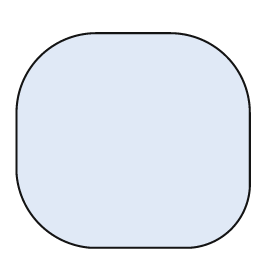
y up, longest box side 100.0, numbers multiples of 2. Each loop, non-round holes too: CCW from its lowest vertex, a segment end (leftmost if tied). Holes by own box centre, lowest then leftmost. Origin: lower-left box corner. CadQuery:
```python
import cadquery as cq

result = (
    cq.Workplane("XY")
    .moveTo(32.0, 0.0)
    .lineTo(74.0, 0.0)
    .threePointArc((92.0, 8.0), (100.0, 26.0))
    .lineTo(100.0, 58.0)
    .threePointArc((90.0, 82.0), (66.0, 92.0))
    .lineTo(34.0, 92.0)
    .threePointArc((10.0, 82.0), (0.0, 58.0))
    .lineTo(0.0, 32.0)
    .threePointArc((10.0, 10.0), (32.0, 0.0))
    .close()
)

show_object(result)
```